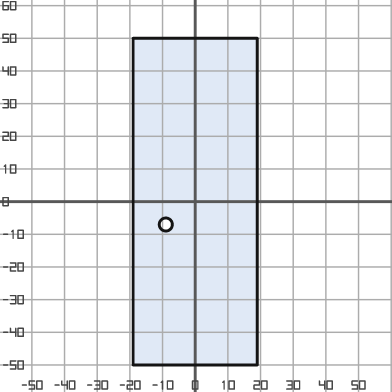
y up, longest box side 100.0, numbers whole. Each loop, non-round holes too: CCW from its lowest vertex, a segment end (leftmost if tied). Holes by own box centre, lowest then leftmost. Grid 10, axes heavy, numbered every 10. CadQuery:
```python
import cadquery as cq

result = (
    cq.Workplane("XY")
    .moveTo(-19.0, -50.0)
    .lineTo(19.0, -50.0)
    .lineTo(19.0, 50.0)
    .lineTo(-19.0, 50.0)
    .close()
    .moveTo(-9.0, -7.0)
    .circle(2.0)
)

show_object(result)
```